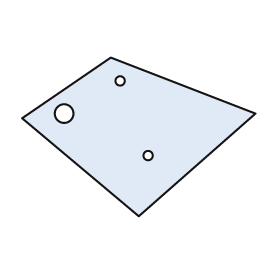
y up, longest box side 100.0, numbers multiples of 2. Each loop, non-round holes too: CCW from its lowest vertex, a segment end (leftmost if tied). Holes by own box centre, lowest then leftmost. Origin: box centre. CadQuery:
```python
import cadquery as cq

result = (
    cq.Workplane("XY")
    .moveTo(0.0, -34.0)
    .lineTo(50.0, 10.0)
    .lineTo(-12.0, 34.0)
    .lineTo(-50.0, 8.0)
    .close()
    .moveTo(4.0, -8.0)
    .circle(2.0)
    .moveTo(-32.0, 10.0)
    .circle(4.0)
    .moveTo(-8.0, 24.0)
    .circle(2.0)
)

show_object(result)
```